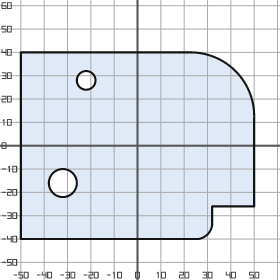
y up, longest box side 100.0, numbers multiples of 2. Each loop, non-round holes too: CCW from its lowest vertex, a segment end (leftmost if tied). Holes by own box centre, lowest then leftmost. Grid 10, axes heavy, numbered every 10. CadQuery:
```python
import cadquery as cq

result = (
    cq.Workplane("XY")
    .moveTo(-50.0, -40.0)
    .lineTo(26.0, -40.0)
    .threePointArc((30.0, -38.0), (32.0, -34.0))
    .lineTo(32.0, -26.0)
    .lineTo(50.0, -26.0)
    .lineTo(50.0, 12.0)
    .threePointArc((42.0, 32.0), (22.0, 40.0))
    .lineTo(-50.0, 40.0)
    .close()
    .moveTo(-32.0, -16.0)
    .circle(6.0)
    .moveTo(-22.0, 28.0)
    .circle(4.0)
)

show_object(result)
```